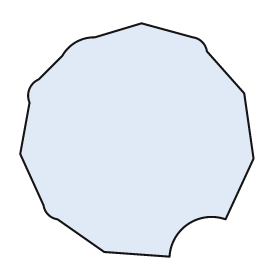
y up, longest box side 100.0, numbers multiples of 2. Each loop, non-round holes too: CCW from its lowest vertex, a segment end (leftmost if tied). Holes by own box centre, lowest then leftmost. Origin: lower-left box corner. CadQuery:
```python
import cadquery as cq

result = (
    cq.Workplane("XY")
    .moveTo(64.0, 0.0)
    .threePointArc((72.0, 14.0), (88.0, 16.0))
    .lineTo(100.0, 42.0)
    .lineTo(96.0, 70.0)
    .lineTo(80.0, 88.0)
    .threePointArc((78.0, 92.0), (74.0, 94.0))
    .lineTo(52.0, 100.0)
    .lineTo(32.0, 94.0)
    .threePointArc((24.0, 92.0), (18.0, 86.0))
    .lineTo(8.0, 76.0)
    .threePointArc((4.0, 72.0), (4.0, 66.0))
    .lineTo(0.0, 44.0)
    .lineTo(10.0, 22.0)
    .threePointArc((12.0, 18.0), (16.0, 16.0))
    .lineTo(36.0, 2.0)
    .close()
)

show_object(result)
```